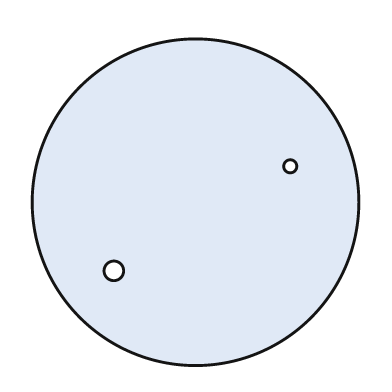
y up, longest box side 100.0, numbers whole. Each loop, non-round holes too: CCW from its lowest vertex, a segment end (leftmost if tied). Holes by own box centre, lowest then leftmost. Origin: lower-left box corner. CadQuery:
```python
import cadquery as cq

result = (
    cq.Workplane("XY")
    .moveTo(50.0, 50.0)
    .circle(50.0)
    .moveTo(25.0, 29.0)
    .circle(3.0)
    .moveTo(79.0, 61.0)
    .circle(2.0)
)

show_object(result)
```